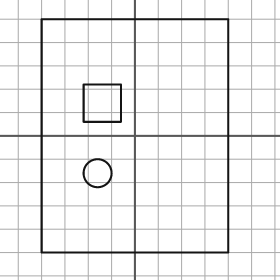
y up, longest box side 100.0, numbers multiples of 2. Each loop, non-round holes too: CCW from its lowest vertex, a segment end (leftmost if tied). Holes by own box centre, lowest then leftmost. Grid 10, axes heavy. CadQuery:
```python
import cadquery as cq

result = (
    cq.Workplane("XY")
    .moveTo(-40.0, -50.0)
    .lineTo(40.0, -50.0)
    .lineTo(40.0, 50.0)
    .lineTo(-40.0, 50.0)
    .close()
    .moveTo(-16.0, -16.0)
    .circle(6.0)
    .moveTo(-22.0, 6.0)
    .lineTo(-6.0, 6.0)
    .lineTo(-6.0, 22.0)
    .lineTo(-22.0, 22.0)
    .close()
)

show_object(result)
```